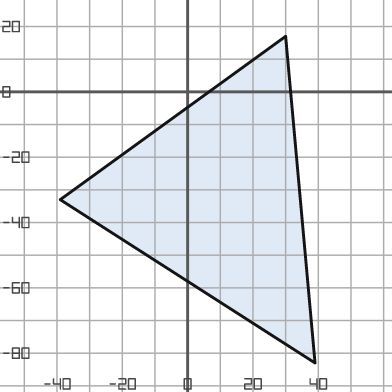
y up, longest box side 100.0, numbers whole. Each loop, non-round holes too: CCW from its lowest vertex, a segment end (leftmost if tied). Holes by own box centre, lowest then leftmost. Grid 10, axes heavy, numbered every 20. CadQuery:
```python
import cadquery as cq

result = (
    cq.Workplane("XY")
    .moveTo(39.0, -83.0)
    .lineTo(30.0, 17.0)
    .lineTo(-39.0, -33.0)
    .close()
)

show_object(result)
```